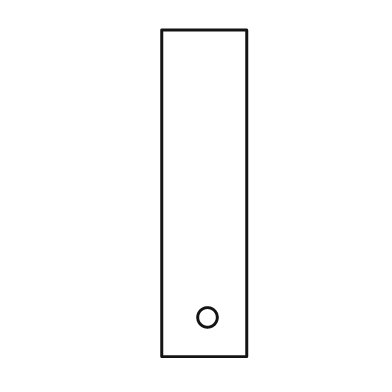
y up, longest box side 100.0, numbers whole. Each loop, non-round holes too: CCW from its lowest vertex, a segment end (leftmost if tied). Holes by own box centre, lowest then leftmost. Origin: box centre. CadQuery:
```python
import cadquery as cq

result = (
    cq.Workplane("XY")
    .moveTo(-13.0, -50.0)
    .lineTo(13.0, -50.0)
    .lineTo(13.0, 50.0)
    .lineTo(-13.0, 50.0)
    .close()
    .moveTo(1.0, -38.0)
    .circle(3.0)
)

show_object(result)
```